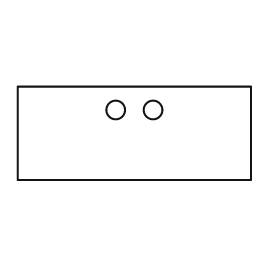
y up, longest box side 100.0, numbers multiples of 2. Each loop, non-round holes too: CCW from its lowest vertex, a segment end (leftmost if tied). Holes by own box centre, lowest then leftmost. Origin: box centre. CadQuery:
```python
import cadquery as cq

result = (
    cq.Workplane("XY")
    .moveTo(-50.0, -20.0)
    .lineTo(50.0, -20.0)
    .lineTo(50.0, 20.0)
    .lineTo(-50.0, 20.0)
    .close()
    .moveTo(-8.0, 10.0)
    .circle(4.0)
    .moveTo(8.0, 10.0)
    .circle(4.0)
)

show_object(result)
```